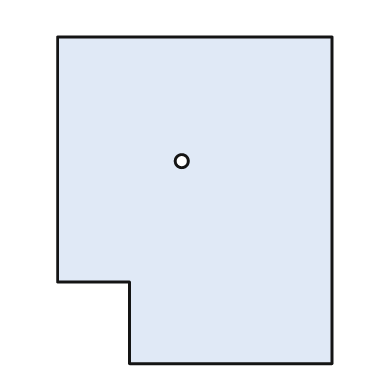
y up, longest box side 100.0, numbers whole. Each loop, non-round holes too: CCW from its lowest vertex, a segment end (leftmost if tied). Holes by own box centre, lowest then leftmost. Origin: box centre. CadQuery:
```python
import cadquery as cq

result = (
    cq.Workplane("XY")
    .moveTo(-20.0, -50.0)
    .lineTo(42.0, -50.0)
    .lineTo(42.0, 50.0)
    .lineTo(-42.0, 50.0)
    .lineTo(-42.0, -25.0)
    .lineTo(-20.0, -25.0)
    .close()
    .moveTo(-4.0, 12.0)
    .circle(2.0)
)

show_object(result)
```